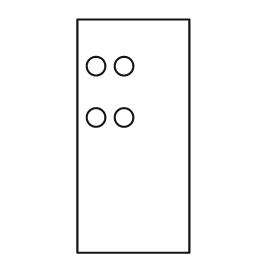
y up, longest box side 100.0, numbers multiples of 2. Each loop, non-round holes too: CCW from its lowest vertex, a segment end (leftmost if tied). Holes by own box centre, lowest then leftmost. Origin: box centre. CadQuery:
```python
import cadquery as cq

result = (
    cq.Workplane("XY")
    .moveTo(-24.0, -50.0)
    .lineTo(24.0, -50.0)
    .lineTo(24.0, 50.0)
    .lineTo(-24.0, 50.0)
    .close()
    .moveTo(-16.0, 8.0)
    .circle(4.0)
    .moveTo(-4.0, 8.0)
    .circle(4.0)
    .moveTo(-16.0, 30.0)
    .circle(4.0)
    .moveTo(-4.0, 30.0)
    .circle(4.0)
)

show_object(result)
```